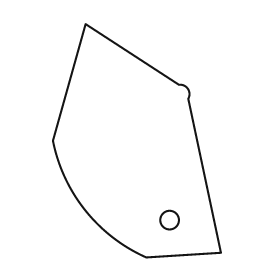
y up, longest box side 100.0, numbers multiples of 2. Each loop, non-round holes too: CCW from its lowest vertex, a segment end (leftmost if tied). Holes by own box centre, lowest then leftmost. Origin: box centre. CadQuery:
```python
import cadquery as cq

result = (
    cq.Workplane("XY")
    .moveTo(4.0, -50.0)
    .lineTo(36.0, -48.0)
    .lineTo(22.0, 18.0)
    .threePointArc((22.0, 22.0), (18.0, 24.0))
    .lineTo(-22.0, 50.0)
    .lineTo(-36.0, 0.0)
    .threePointArc((-22.0, -30.0), (4.0, -50.0))
    .close()
    .moveTo(14.0, -34.0)
    .circle(4.0)
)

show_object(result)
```